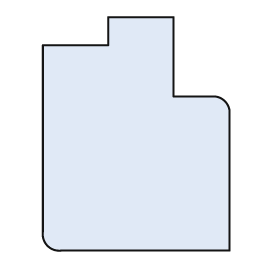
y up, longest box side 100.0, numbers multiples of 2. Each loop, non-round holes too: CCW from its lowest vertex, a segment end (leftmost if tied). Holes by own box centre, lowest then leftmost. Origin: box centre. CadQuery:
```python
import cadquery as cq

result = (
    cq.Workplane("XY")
    .moveTo(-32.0, -50.0)
    .lineTo(40.0, -50.0)
    .lineTo(40.0, 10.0)
    .threePointArc((38.0, 14.0), (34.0, 16.0))
    .lineTo(16.0, 16.0)
    .lineTo(16.0, 50.0)
    .lineTo(-12.0, 50.0)
    .lineTo(-12.0, 38.0)
    .lineTo(-40.0, 38.0)
    .lineTo(-40.0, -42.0)
    .threePointArc((-38.0, -48.0), (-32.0, -50.0))
    .close()
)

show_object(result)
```